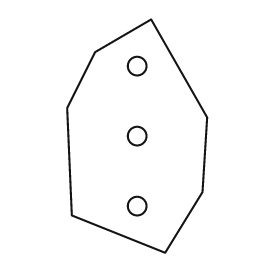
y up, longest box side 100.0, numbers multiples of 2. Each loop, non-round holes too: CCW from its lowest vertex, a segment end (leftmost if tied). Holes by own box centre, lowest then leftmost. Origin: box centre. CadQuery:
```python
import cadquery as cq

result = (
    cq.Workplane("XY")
    .moveTo(12.0, -50.0)
    .lineTo(28.0, -24.0)
    .lineTo(30.0, 8.0)
    .lineTo(6.0, 50.0)
    .lineTo(-18.0, 36.0)
    .lineTo(-30.0, 12.0)
    .lineTo(-28.0, -34.0)
    .close()
    .moveTo(0.0, -30.0)
    .circle(4.0)
    .moveTo(0.0, 0.0)
    .circle(4.0)
    .moveTo(0.0, 30.0)
    .circle(4.0)
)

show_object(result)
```